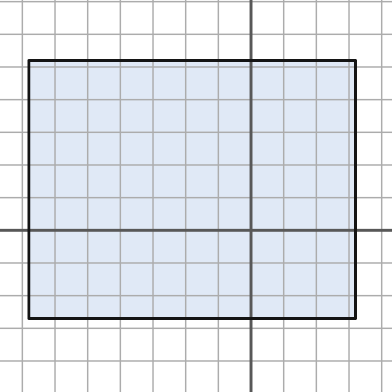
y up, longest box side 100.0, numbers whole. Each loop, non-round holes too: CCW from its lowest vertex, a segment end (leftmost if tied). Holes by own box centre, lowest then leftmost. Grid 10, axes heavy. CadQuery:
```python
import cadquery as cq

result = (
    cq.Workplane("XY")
    .moveTo(-68.0, -27.0)
    .lineTo(32.0, -27.0)
    .lineTo(32.0, 52.0)
    .lineTo(-68.0, 52.0)
    .close()
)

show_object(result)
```